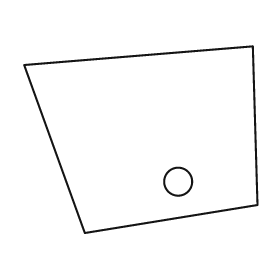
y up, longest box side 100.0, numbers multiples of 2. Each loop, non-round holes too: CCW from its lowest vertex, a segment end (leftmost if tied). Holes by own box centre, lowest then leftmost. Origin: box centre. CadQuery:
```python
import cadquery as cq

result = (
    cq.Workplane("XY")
    .moveTo(-24.0, -40.0)
    .lineTo(50.0, -28.0)
    .lineTo(48.0, 40.0)
    .lineTo(-50.0, 32.0)
    .close()
    .moveTo(16.0, -18.0)
    .circle(6.0)
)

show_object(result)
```